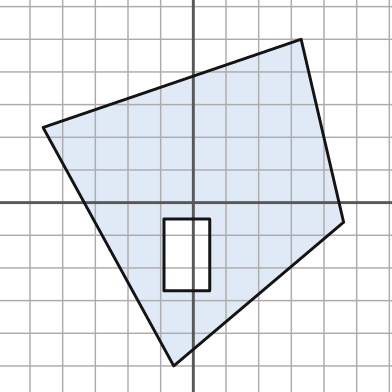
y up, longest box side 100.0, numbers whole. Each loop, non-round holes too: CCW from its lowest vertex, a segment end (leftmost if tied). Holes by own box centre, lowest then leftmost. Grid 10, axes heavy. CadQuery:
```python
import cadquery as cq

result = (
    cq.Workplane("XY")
    .moveTo(-6.0, -50.0)
    .lineTo(46.0, -6.0)
    .lineTo(33.0, 50.0)
    .lineTo(-46.0, 23.0)
    .close()
    .moveTo(-9.0, -27.0)
    .lineTo(5.0, -27.0)
    .lineTo(5.0, -5.0)
    .lineTo(-9.0, -5.0)
    .close()
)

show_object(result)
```